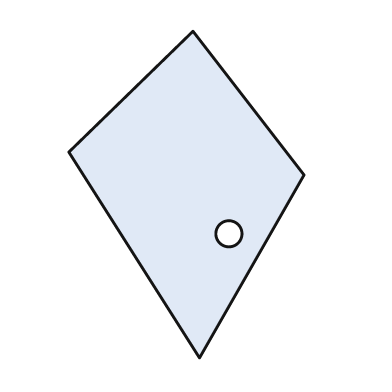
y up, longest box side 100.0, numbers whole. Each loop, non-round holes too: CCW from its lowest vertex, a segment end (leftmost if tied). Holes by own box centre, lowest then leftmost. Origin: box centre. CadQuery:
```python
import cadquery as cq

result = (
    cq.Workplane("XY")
    .moveTo(4.0, -50.0)
    .lineTo(36.0, 6.0)
    .lineTo(2.0, 50.0)
    .lineTo(-36.0, 13.0)
    .close()
    .moveTo(13.0, -12.0)
    .circle(4.0)
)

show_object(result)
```